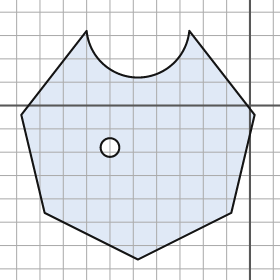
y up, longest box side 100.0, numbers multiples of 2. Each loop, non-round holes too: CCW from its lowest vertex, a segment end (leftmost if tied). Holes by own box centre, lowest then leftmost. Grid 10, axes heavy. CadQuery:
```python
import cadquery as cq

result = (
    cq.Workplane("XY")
    .moveTo(-48.0, -66.0)
    .lineTo(-8.0, -46.0)
    .lineTo(2.0, -4.0)
    .lineTo(-26.0, 32.0)
    .threePointArc((-48.0, 12.0), (-70.0, 32.0))
    .lineTo(-98.0, -4.0)
    .lineTo(-88.0, -46.0)
    .close()
    .moveTo(-60.0, -18.0)
    .circle(4.0)
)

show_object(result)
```